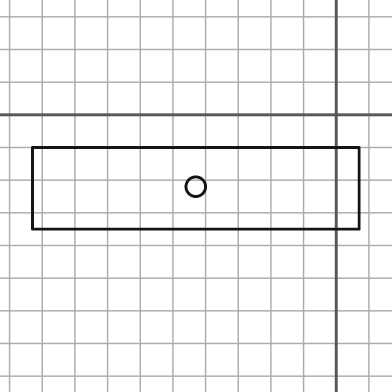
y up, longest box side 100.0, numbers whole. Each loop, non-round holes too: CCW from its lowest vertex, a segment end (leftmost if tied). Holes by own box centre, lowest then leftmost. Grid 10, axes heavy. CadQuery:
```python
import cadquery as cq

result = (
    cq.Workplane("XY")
    .moveTo(-93.0, -35.0)
    .lineTo(7.0, -35.0)
    .lineTo(7.0, -10.0)
    .lineTo(-93.0, -10.0)
    .close()
    .moveTo(-43.0, -22.0)
    .circle(3.0)
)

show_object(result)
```